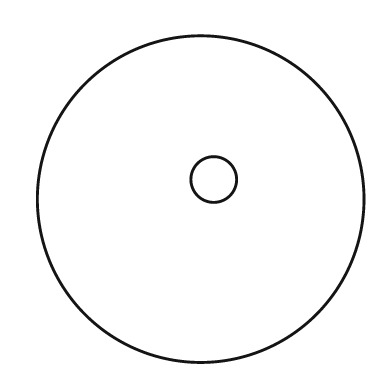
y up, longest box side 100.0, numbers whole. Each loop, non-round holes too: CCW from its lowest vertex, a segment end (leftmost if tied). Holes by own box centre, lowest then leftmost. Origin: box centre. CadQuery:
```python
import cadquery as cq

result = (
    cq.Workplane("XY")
    .moveTo(0.0, 0.0)
    .circle(50.0)
    .moveTo(4.0, 6.0)
    .circle(7.0)
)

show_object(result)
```